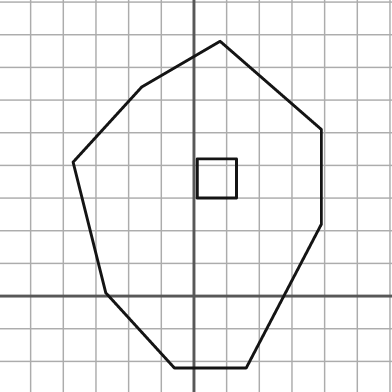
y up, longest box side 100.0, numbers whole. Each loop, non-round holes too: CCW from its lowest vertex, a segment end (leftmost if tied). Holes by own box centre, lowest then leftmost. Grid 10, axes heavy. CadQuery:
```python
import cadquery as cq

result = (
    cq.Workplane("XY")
    .moveTo(-6.0, -22.0)
    .lineTo(16.0, -22.0)
    .lineTo(39.0, 22.0)
    .lineTo(39.0, 51.0)
    .lineTo(8.0, 78.0)
    .lineTo(-16.0, 64.0)
    .lineTo(-37.0, 41.0)
    .lineTo(-27.0, 1.0)
    .close()
    .moveTo(1.0, 30.0)
    .lineTo(13.0, 30.0)
    .lineTo(13.0, 42.0)
    .lineTo(1.0, 42.0)
    .close()
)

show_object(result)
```